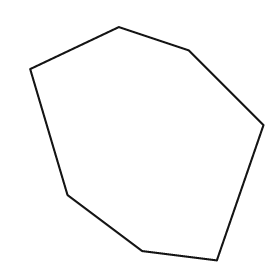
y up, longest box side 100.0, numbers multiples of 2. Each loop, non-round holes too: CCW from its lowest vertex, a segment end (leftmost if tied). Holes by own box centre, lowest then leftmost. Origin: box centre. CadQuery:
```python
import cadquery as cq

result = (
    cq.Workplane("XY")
    .moveTo(30.0, -50.0)
    .lineTo(50.0, 8.0)
    .lineTo(18.0, 40.0)
    .lineTo(-12.0, 50.0)
    .lineTo(-50.0, 32.0)
    .lineTo(-34.0, -22.0)
    .lineTo(-2.0, -46.0)
    .close()
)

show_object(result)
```